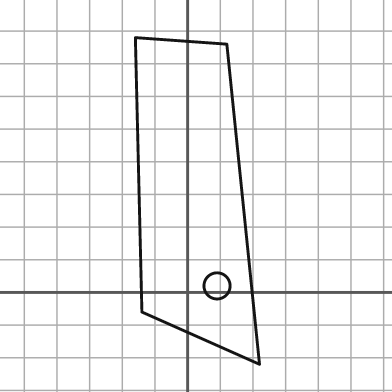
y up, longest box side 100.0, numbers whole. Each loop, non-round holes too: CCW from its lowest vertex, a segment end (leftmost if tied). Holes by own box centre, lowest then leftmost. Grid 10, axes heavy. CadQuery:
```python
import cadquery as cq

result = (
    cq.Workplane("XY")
    .moveTo(22.0, -22.0)
    .lineTo(12.0, 76.0)
    .lineTo(-16.0, 78.0)
    .lineTo(-14.0, -6.0)
    .close()
    .moveTo(9.0, 2.0)
    .circle(4.0)
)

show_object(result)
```